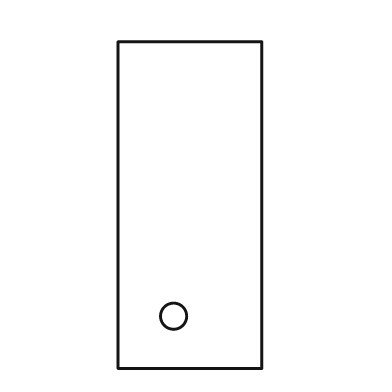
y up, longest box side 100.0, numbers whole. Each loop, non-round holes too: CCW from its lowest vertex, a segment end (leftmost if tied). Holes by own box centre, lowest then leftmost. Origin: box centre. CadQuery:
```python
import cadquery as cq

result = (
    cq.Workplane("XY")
    .moveTo(-22.0, -50.0)
    .lineTo(22.0, -50.0)
    .lineTo(22.0, 50.0)
    .lineTo(-22.0, 50.0)
    .close()
    .moveTo(-5.0, -34.0)
    .circle(4.0)
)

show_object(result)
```